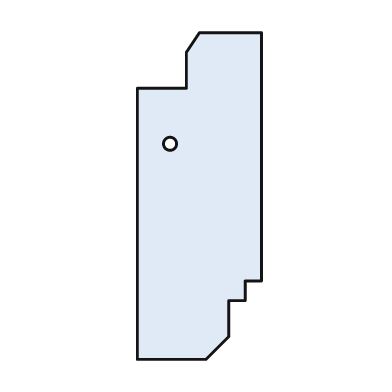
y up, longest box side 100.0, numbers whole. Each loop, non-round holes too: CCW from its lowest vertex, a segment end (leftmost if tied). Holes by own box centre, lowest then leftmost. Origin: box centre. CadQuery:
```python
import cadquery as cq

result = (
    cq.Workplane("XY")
    .moveTo(-19.0, -50.0)
    .lineTo(2.0, -50.0)
    .lineTo(9.0, -43.0)
    .lineTo(9.0, -32.0)
    .lineTo(14.0, -32.0)
    .lineTo(14.0, -26.0)
    .lineTo(19.0, -26.0)
    .lineTo(19.0, 50.0)
    .lineTo(0.0, 50.0)
    .lineTo(-4.0, 44.0)
    .lineTo(-4.0, 33.0)
    .lineTo(-19.0, 33.0)
    .close()
    .moveTo(-9.0, 16.0)
    .circle(2.0)
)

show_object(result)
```